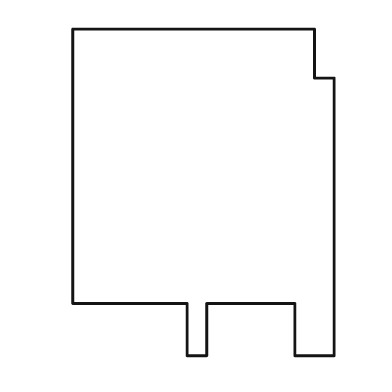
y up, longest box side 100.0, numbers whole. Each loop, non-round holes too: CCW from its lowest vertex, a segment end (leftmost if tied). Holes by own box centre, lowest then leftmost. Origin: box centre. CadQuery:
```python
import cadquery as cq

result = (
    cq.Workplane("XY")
    .moveTo(-5.0, -50.0)
    .lineTo(1.0, -50.0)
    .lineTo(1.0, -34.0)
    .lineTo(28.0, -34.0)
    .lineTo(28.0, -50.0)
    .lineTo(40.0, -50.0)
    .lineTo(40.0, 35.0)
    .lineTo(34.0, 35.0)
    .lineTo(34.0, 50.0)
    .lineTo(-40.0, 50.0)
    .lineTo(-40.0, -34.0)
    .lineTo(-5.0, -34.0)
    .close()
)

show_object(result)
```